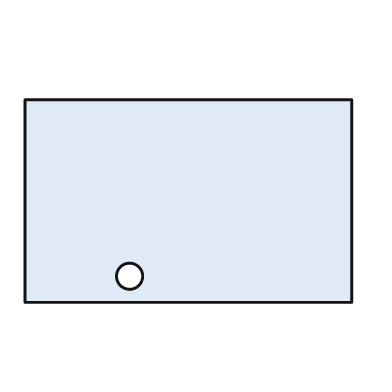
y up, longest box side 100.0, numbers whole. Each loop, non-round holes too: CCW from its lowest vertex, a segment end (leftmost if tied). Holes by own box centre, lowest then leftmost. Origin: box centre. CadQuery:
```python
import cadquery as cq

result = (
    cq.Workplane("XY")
    .moveTo(-50.0, -31.0)
    .lineTo(50.0, -31.0)
    .lineTo(50.0, 31.0)
    .lineTo(-50.0, 31.0)
    .close()
    .moveTo(-18.0, -23.0)
    .circle(4.0)
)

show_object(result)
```